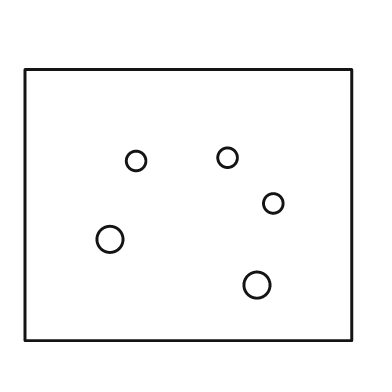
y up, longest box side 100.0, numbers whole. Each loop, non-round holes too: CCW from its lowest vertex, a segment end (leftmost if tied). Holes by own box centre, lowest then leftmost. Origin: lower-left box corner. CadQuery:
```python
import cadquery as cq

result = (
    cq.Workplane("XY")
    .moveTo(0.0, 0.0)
    .lineTo(100.0, 0.0)
    .lineTo(100.0, 83.0)
    .lineTo(0.0, 83.0)
    .close()
    .moveTo(71.0, 17.0)
    .circle(4.0)
    .moveTo(26.0, 31.0)
    .circle(4.0)
    .moveTo(76.0, 42.0)
    .circle(3.0)
    .moveTo(34.0, 55.0)
    .circle(3.0)
    .moveTo(62.0, 56.0)
    .circle(3.0)
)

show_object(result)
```